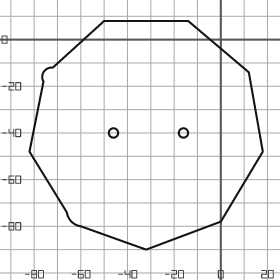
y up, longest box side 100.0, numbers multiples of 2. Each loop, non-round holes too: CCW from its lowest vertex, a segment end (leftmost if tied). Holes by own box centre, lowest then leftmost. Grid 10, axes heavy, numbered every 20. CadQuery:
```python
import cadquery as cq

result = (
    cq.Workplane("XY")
    .moveTo(-32.0, -90.0)
    .lineTo(0.0, -78.0)
    .lineTo(18.0, -48.0)
    .lineTo(12.0, -14.0)
    .lineTo(-14.0, 8.0)
    .lineTo(-50.0, 8.0)
    .lineTo(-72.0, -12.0)
    .threePointArc((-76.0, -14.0), (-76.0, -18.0))
    .lineTo(-82.0, -48.0)
    .lineTo(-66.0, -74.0)
    .threePointArc((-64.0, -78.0), (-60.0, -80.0))
    .close()
    .moveTo(-46.0, -40.0)
    .circle(2.0)
    .moveTo(-16.0, -40.0)
    .circle(2.0)
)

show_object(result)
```